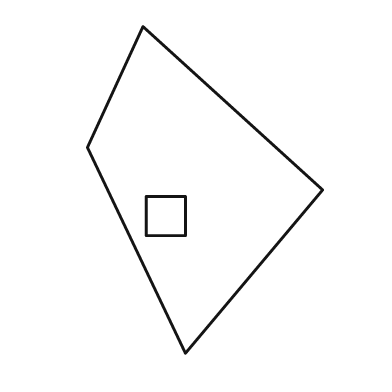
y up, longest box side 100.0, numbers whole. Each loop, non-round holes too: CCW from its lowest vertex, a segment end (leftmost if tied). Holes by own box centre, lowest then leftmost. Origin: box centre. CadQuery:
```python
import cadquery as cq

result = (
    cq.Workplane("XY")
    .moveTo(-6.0, -50.0)
    .lineTo(36.0, 0.0)
    .lineTo(-19.0, 50.0)
    .lineTo(-36.0, 13.0)
    .close()
    .moveTo(-18.0, -14.0)
    .lineTo(-6.0, -14.0)
    .lineTo(-6.0, -2.0)
    .lineTo(-18.0, -2.0)
    .close()
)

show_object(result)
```